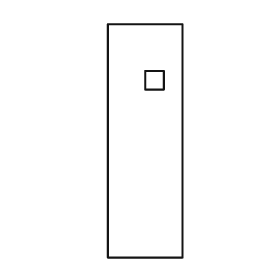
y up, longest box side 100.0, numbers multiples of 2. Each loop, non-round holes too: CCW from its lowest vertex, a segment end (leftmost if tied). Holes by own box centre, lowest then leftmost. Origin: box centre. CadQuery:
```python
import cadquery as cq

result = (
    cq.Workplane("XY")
    .moveTo(-16.0, -50.0)
    .lineTo(16.0, -50.0)
    .lineTo(16.0, 50.0)
    .lineTo(-16.0, 50.0)
    .close()
    .moveTo(0.0, 22.0)
    .lineTo(8.0, 22.0)
    .lineTo(8.0, 30.0)
    .lineTo(0.0, 30.0)
    .close()
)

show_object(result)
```